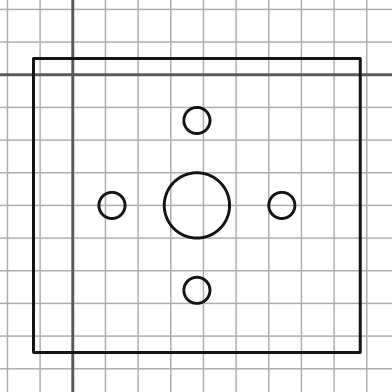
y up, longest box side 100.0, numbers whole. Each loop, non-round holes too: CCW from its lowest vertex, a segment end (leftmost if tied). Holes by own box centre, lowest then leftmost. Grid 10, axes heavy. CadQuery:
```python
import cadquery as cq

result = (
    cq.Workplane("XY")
    .moveTo(-12.0, -85.0)
    .lineTo(88.0, -85.0)
    .lineTo(88.0, 5.0)
    .lineTo(-12.0, 5.0)
    .close()
    .moveTo(38.0, -66.0)
    .circle(4.0)
    .moveTo(12.0, -40.0)
    .circle(4.0)
    .moveTo(38.0, -40.0)
    .circle(10.0)
    .moveTo(64.0, -40.0)
    .circle(4.0)
    .moveTo(38.0, -14.0)
    .circle(4.0)
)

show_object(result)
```